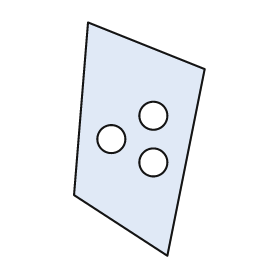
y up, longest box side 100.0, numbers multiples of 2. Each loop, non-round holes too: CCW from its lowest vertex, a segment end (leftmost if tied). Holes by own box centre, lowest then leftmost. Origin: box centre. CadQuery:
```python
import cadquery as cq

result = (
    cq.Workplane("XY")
    .moveTo(12.0, -50.0)
    .lineTo(28.0, 30.0)
    .lineTo(-22.0, 50.0)
    .lineTo(-28.0, -24.0)
    .close()
    .moveTo(6.0, -10.0)
    .circle(6.0)
    .moveTo(-12.0, 0.0)
    .circle(6.0)
    .moveTo(6.0, 10.0)
    .circle(6.0)
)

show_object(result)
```